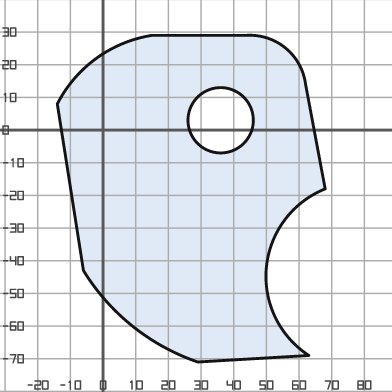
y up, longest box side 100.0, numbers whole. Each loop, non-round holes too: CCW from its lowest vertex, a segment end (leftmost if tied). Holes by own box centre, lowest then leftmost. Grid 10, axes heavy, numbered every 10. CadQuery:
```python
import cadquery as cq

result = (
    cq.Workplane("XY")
    .moveTo(29.0, -71.0)
    .lineTo(63.0, -69.0)
    .threePointArc((50.0, -42.0), (68.0, -18.0))
    .lineTo(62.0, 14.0)
    .threePointArc((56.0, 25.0), (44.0, 29.0))
    .lineTo(15.0, 29.0)
    .threePointArc((-2.0, 22.0), (-14.0, 8.0))
    .lineTo(-6.0, -43.0)
    .threePointArc((9.0, -60.0), (29.0, -71.0))
    .close()
    .moveTo(36.0, 3.0)
    .circle(10.0)
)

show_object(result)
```